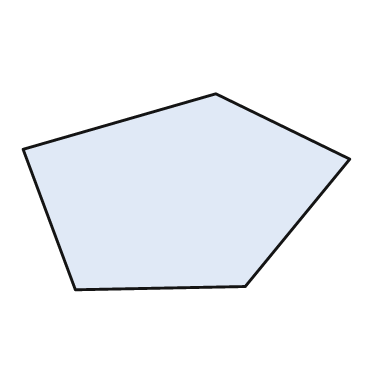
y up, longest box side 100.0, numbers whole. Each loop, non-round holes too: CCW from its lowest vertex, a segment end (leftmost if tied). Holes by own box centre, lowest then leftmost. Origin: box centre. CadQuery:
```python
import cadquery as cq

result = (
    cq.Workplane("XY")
    .moveTo(-34.0, -30.0)
    .lineTo(18.0, -29.0)
    .lineTo(50.0, 10.0)
    .lineTo(9.0, 30.0)
    .lineTo(-50.0, 13.0)
    .close()
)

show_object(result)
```